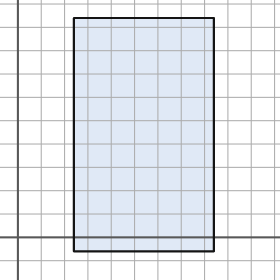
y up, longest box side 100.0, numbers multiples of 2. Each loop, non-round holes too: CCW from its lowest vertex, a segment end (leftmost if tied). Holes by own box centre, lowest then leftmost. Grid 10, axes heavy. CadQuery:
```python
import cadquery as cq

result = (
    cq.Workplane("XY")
    .moveTo(24.0, -6.0)
    .lineTo(84.0, -6.0)
    .lineTo(84.0, 94.0)
    .lineTo(24.0, 94.0)
    .close()
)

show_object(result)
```